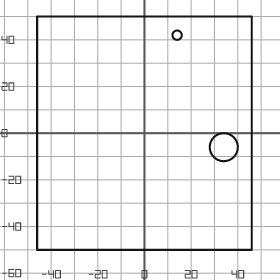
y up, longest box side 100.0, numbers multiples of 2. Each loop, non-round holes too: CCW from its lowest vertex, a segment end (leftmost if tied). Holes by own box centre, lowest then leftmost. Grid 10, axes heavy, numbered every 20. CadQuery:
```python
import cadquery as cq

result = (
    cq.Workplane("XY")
    .moveTo(-46.0, -50.0)
    .lineTo(46.0, -50.0)
    .lineTo(46.0, 50.0)
    .lineTo(-46.0, 50.0)
    .close()
    .moveTo(34.0, -6.0)
    .circle(6.0)
    .moveTo(14.0, 42.0)
    .circle(2.0)
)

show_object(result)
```